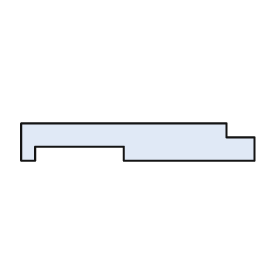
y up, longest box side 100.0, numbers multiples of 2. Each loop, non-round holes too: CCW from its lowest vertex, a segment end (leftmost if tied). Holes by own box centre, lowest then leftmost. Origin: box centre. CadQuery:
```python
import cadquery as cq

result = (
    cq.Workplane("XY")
    .moveTo(-50.0, -8.0)
    .lineTo(-44.0, -8.0)
    .lineTo(-44.0, -2.0)
    .lineTo(-6.0, -2.0)
    .lineTo(-6.0, -8.0)
    .lineTo(50.0, -8.0)
    .lineTo(50.0, 2.0)
    .lineTo(38.0, 2.0)
    .lineTo(38.0, 8.0)
    .lineTo(-50.0, 8.0)
    .close()
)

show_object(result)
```